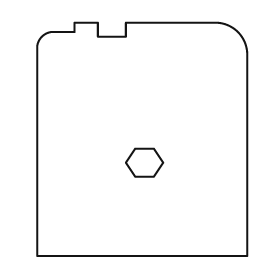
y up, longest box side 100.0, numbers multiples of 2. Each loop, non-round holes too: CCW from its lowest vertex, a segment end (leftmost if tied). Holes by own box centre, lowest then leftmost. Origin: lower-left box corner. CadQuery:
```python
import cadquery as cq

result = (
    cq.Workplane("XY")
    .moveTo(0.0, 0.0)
    .lineTo(90.0, 0.0)
    .lineTo(90.0, 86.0)
    .threePointArc((86.0, 96.0), (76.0, 100.0))
    .lineTo(38.0, 100.0)
    .lineTo(38.0, 94.0)
    .lineTo(26.0, 94.0)
    .lineTo(26.0, 100.0)
    .lineTo(16.0, 100.0)
    .lineTo(16.0, 96.0)
    .lineTo(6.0, 96.0)
    .threePointArc((2.0, 94.0), (0.0, 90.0))
    .close()
    .moveTo(42.0, 34.0)
    .lineTo(50.0, 34.0)
    .lineTo(54.0, 40.0)
    .lineTo(50.0, 46.0)
    .lineTo(42.0, 46.0)
    .lineTo(38.0, 40.0)
    .close()
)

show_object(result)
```